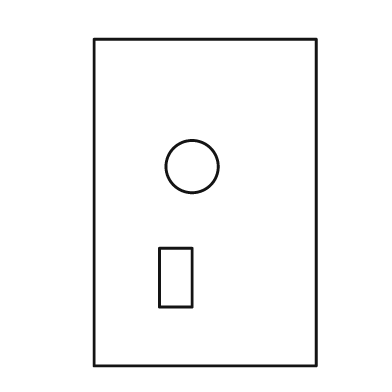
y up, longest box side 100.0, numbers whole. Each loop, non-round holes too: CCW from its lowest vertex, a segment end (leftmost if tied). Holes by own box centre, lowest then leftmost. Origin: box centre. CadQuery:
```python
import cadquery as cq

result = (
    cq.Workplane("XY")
    .moveTo(-34.0, -50.0)
    .lineTo(34.0, -50.0)
    .lineTo(34.0, 50.0)
    .lineTo(-34.0, 50.0)
    .close()
    .moveTo(-14.0, -32.0)
    .lineTo(-4.0, -32.0)
    .lineTo(-4.0, -14.0)
    .lineTo(-14.0, -14.0)
    .close()
    .moveTo(-4.0, 11.0)
    .circle(8.0)
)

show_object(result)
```